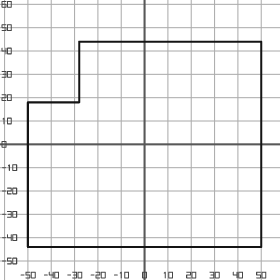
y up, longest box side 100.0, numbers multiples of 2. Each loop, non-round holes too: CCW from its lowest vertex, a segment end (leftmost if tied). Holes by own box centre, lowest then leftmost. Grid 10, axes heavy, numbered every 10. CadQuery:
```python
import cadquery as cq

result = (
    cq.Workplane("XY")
    .moveTo(-50.0, -44.0)
    .lineTo(50.0, -44.0)
    .lineTo(50.0, 44.0)
    .lineTo(-28.0, 44.0)
    .lineTo(-28.0, 18.0)
    .lineTo(-50.0, 18.0)
    .close()
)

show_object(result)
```